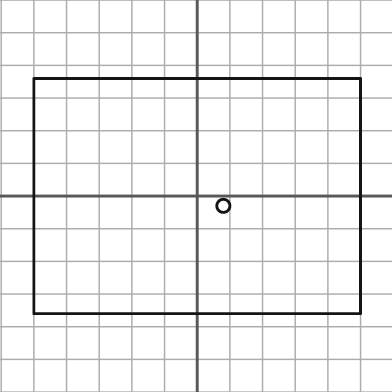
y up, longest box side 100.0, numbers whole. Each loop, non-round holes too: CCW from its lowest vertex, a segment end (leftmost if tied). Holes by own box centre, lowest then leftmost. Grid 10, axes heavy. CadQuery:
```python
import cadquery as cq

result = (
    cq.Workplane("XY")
    .moveTo(-50.0, -36.0)
    .lineTo(50.0, -36.0)
    .lineTo(50.0, 36.0)
    .lineTo(-50.0, 36.0)
    .close()
    .moveTo(8.0, -3.0)
    .circle(2.0)
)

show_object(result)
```